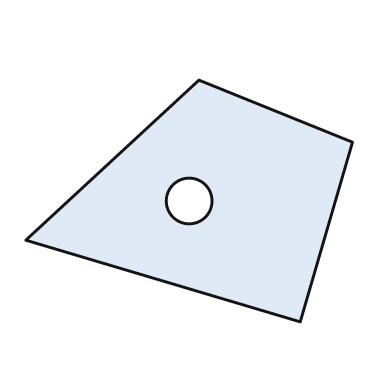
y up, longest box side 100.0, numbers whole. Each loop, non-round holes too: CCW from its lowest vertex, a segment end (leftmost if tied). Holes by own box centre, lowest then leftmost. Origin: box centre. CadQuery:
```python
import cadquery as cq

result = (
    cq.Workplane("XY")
    .moveTo(34.0, -37.0)
    .lineTo(50.0, 18.0)
    .lineTo(3.0, 37.0)
    .lineTo(-50.0, -12.0)
    .close()
    .moveTo(0.0, 0.0)
    .circle(7.0)
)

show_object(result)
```